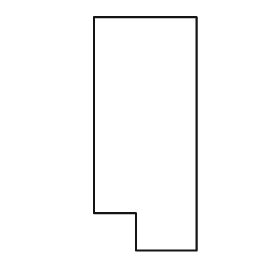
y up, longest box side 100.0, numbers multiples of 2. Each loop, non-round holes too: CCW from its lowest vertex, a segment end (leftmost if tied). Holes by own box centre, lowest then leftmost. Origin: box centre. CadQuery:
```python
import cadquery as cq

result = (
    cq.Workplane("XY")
    .moveTo(-4.0, -50.0)
    .lineTo(22.0, -50.0)
    .lineTo(22.0, 50.0)
    .lineTo(-22.0, 50.0)
    .lineTo(-22.0, -34.0)
    .lineTo(-4.0, -34.0)
    .close()
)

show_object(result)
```